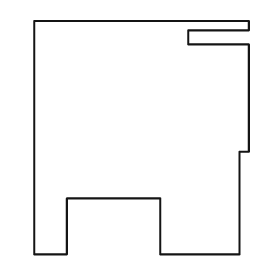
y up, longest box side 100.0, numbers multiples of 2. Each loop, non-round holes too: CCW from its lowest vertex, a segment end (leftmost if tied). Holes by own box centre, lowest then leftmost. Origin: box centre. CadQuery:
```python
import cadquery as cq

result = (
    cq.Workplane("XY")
    .moveTo(-46.0, -50.0)
    .lineTo(-32.0, -50.0)
    .lineTo(-32.0, -26.0)
    .lineTo(8.0, -26.0)
    .lineTo(8.0, -50.0)
    .lineTo(42.0, -50.0)
    .lineTo(42.0, -6.0)
    .lineTo(46.0, -6.0)
    .lineTo(46.0, 40.0)
    .lineTo(20.0, 40.0)
    .lineTo(20.0, 46.0)
    .lineTo(46.0, 46.0)
    .lineTo(46.0, 50.0)
    .lineTo(-46.0, 50.0)
    .close()
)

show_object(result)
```